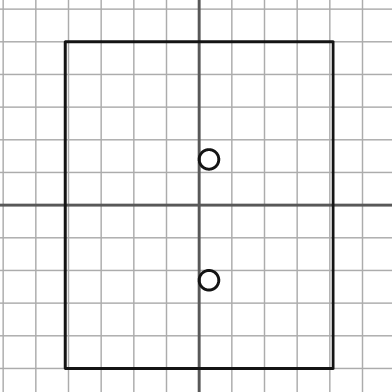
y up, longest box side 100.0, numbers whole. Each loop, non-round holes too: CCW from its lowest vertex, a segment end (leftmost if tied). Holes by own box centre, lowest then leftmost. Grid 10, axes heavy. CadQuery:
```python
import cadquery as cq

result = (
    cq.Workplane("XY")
    .moveTo(-41.0, -50.0)
    .lineTo(41.0, -50.0)
    .lineTo(41.0, 50.0)
    .lineTo(-41.0, 50.0)
    .close()
    .moveTo(3.0, -23.0)
    .circle(3.0)
    .moveTo(3.0, 14.0)
    .circle(3.0)
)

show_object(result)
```